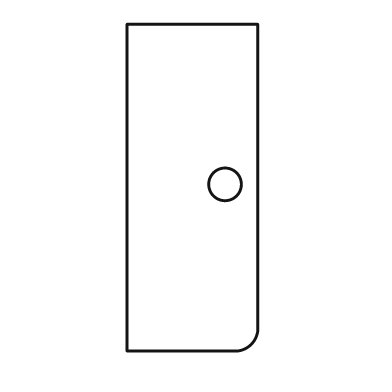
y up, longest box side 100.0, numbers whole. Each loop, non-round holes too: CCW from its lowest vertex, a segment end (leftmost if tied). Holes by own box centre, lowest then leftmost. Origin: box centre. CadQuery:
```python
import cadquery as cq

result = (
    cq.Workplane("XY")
    .moveTo(-20.0, -50.0)
    .lineTo(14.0, -50.0)
    .threePointArc((18.0, -48.0), (20.0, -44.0))
    .lineTo(20.0, 50.0)
    .lineTo(-20.0, 50.0)
    .close()
    .moveTo(10.0, 1.0)
    .circle(5.0)
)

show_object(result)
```